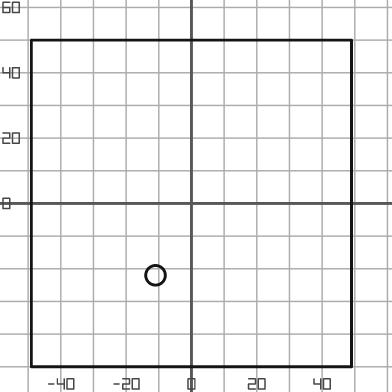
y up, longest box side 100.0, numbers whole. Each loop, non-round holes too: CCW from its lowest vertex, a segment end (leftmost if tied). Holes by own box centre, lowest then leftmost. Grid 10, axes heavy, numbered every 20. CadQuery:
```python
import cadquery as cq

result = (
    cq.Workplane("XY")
    .moveTo(-49.0, -50.0)
    .lineTo(49.0, -50.0)
    .lineTo(49.0, 50.0)
    .lineTo(-49.0, 50.0)
    .close()
    .moveTo(-11.0, -22.0)
    .circle(3.0)
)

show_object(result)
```